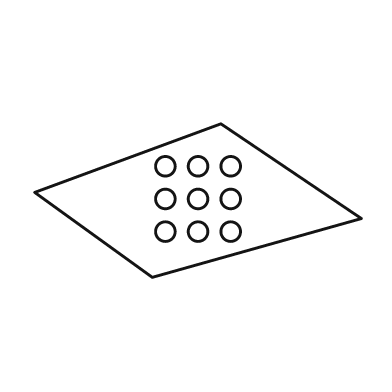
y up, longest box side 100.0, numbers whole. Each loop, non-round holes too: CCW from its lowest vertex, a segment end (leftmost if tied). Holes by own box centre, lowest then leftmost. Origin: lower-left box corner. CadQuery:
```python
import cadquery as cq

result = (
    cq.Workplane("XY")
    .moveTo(36.0, 0.0)
    .lineTo(100.0, 18.0)
    .lineTo(57.0, 47.0)
    .lineTo(0.0, 26.0)
    .close()
    .moveTo(40.0, 14.0)
    .circle(3.0)
    .moveTo(50.0, 14.0)
    .circle(3.0)
    .moveTo(60.0, 14.0)
    .circle(3.0)
    .moveTo(40.0, 24.0)
    .circle(3.0)
    .moveTo(50.0, 24.0)
    .circle(3.0)
    .moveTo(60.0, 24.0)
    .circle(3.0)
    .moveTo(40.0, 34.0)
    .circle(3.0)
    .moveTo(50.0, 34.0)
    .circle(3.0)
    .moveTo(60.0, 34.0)
    .circle(3.0)
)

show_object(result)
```